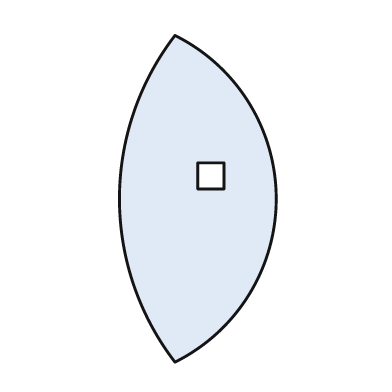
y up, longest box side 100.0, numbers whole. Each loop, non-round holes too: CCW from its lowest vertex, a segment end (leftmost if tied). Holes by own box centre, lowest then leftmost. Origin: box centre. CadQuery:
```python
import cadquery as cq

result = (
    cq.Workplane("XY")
    .moveTo(-7.0, -50.0)
    .threePointArc((24.0, 0.0), (-7.0, 50.0))
    .threePointArc((-24.0, 0.0), (-7.0, -50.0))
    .close()
    .moveTo(0.0, 3.0)
    .lineTo(8.0, 3.0)
    .lineTo(8.0, 11.0)
    .lineTo(0.0, 11.0)
    .close()
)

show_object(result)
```